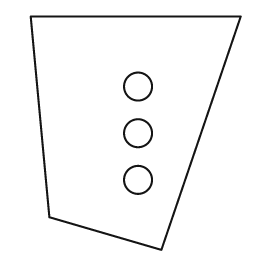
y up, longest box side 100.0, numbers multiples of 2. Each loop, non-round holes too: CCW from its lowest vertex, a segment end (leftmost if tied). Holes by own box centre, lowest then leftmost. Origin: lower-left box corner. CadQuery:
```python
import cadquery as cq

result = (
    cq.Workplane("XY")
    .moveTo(56.0, 0.0)
    .lineTo(90.0, 100.0)
    .lineTo(0.0, 100.0)
    .lineTo(8.0, 14.0)
    .close()
    .moveTo(46.0, 30.0)
    .circle(6.0)
    .moveTo(46.0, 50.0)
    .circle(6.0)
    .moveTo(46.0, 70.0)
    .circle(6.0)
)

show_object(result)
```